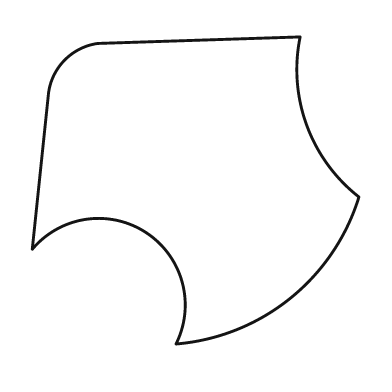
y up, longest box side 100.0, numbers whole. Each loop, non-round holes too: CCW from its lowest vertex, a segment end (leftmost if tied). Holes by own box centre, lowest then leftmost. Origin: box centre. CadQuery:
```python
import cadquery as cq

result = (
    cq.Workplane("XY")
    .moveTo(-6.0, -47.0)
    .threePointArc((29.0, -33.0), (50.0, -2.0))
    .threePointArc((34.0, 20.0), (32.0, 47.0))
    .lineTo(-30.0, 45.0)
    .threePointArc((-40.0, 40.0), (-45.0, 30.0))
    .lineTo(-50.0, -18.0)
    .threePointArc((-15.0, -13.0), (-6.0, -47.0))
    .close()
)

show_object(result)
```